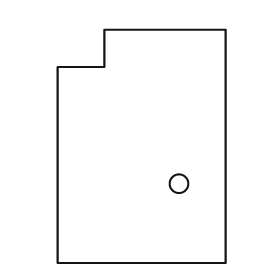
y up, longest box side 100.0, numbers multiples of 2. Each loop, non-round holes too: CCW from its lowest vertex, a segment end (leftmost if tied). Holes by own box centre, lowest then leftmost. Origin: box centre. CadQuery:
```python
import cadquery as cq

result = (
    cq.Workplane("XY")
    .moveTo(-36.0, -50.0)
    .lineTo(36.0, -50.0)
    .lineTo(36.0, 50.0)
    .lineTo(-16.0, 50.0)
    .lineTo(-16.0, 34.0)
    .lineTo(-36.0, 34.0)
    .close()
    .moveTo(16.0, -16.0)
    .circle(4.0)
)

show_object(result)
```